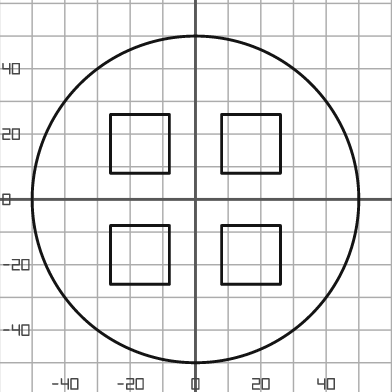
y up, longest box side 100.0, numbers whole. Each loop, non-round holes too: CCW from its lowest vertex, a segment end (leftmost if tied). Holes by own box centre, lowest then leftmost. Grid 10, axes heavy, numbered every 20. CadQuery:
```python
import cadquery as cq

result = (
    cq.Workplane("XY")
    .moveTo(0.0, 0.0)
    .circle(50.0)
    .moveTo(-26.0, -26.0)
    .lineTo(-8.0, -26.0)
    .lineTo(-8.0, -8.0)
    .lineTo(-26.0, -8.0)
    .close()
    .moveTo(8.0, -26.0)
    .lineTo(26.0, -26.0)
    .lineTo(26.0, -8.0)
    .lineTo(8.0, -8.0)
    .close()
    .moveTo(-26.0, 8.0)
    .lineTo(-8.0, 8.0)
    .lineTo(-8.0, 26.0)
    .lineTo(-26.0, 26.0)
    .close()
    .moveTo(8.0, 8.0)
    .lineTo(26.0, 8.0)
    .lineTo(26.0, 26.0)
    .lineTo(8.0, 26.0)
    .close()
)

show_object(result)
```